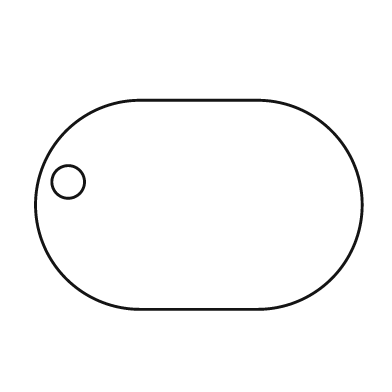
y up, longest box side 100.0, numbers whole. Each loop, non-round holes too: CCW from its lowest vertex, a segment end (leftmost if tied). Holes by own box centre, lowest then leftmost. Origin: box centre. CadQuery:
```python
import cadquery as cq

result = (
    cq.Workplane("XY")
    .moveTo(-18.0, -32.0)
    .lineTo(18.0, -32.0)
    .threePointArc((50.0, 0.0), (18.0, 32.0))
    .lineTo(-18.0, 32.0)
    .threePointArc((-50.0, 0.0), (-18.0, -32.0))
    .close()
    .moveTo(-40.0, 7.0)
    .circle(5.0)
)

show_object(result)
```